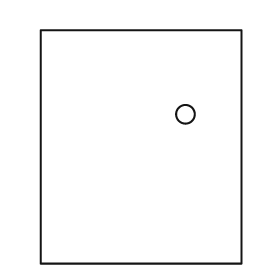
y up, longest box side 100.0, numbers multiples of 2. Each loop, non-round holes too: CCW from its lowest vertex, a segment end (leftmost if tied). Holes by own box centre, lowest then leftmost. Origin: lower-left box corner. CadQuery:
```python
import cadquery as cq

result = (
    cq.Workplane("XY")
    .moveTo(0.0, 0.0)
    .lineTo(86.0, 0.0)
    .lineTo(86.0, 100.0)
    .lineTo(0.0, 100.0)
    .close()
    .moveTo(62.0, 64.0)
    .circle(4.0)
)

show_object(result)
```